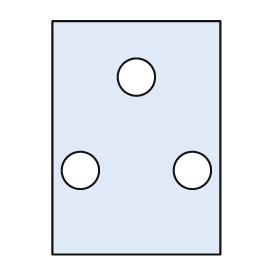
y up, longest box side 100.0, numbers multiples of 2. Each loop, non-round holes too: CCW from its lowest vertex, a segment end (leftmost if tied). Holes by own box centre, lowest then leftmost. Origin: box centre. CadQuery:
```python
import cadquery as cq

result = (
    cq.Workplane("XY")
    .moveTo(-36.0, -50.0)
    .lineTo(36.0, -50.0)
    .lineTo(36.0, 50.0)
    .lineTo(-36.0, 50.0)
    .close()
    .moveTo(-24.0, -14.0)
    .circle(8.0)
    .moveTo(24.0, -14.0)
    .circle(8.0)
    .moveTo(0.0, 26.0)
    .circle(8.0)
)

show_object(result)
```